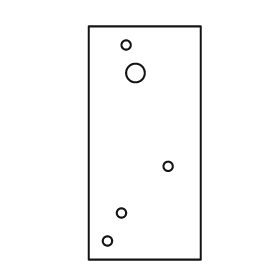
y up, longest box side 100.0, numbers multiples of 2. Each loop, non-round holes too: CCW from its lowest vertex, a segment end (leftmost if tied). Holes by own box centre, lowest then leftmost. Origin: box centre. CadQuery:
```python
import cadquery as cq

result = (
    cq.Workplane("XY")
    .moveTo(-24.0, -50.0)
    .lineTo(24.0, -50.0)
    .lineTo(24.0, 50.0)
    .lineTo(-24.0, 50.0)
    .close()
    .moveTo(-16.0, -42.0)
    .circle(2.0)
    .moveTo(-10.0, -30.0)
    .circle(2.0)
    .moveTo(10.0, -10.0)
    .circle(2.0)
    .moveTo(-4.0, 30.0)
    .circle(4.0)
    .moveTo(-8.0, 42.0)
    .circle(2.0)
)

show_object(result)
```